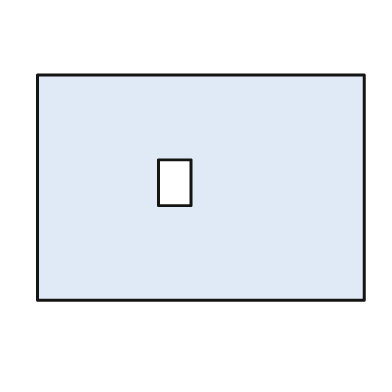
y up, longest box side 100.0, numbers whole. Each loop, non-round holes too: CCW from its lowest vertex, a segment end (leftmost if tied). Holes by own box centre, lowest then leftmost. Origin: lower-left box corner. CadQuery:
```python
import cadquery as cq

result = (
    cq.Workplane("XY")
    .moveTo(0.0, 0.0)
    .lineTo(100.0, 0.0)
    .lineTo(100.0, 69.0)
    .lineTo(0.0, 69.0)
    .close()
    .moveTo(37.0, 29.0)
    .lineTo(47.0, 29.0)
    .lineTo(47.0, 43.0)
    .lineTo(37.0, 43.0)
    .close()
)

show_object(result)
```